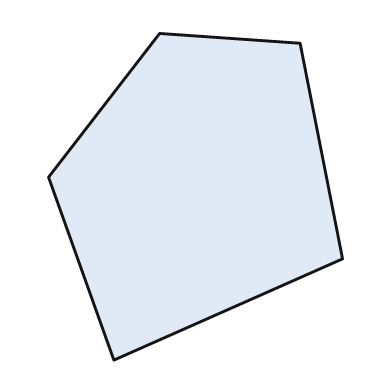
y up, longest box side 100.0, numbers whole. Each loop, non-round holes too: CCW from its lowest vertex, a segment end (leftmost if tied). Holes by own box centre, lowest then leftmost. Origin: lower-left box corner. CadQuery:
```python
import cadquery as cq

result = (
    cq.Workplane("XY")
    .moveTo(20.0, 0.0)
    .lineTo(90.0, 31.0)
    .lineTo(77.0, 97.0)
    .lineTo(34.0, 100.0)
    .lineTo(0.0, 56.0)
    .close()
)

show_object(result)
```